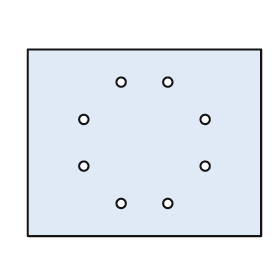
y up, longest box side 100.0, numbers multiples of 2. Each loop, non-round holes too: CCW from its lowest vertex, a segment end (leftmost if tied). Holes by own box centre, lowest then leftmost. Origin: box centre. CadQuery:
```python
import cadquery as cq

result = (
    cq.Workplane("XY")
    .moveTo(-50.0, -40.0)
    .lineTo(50.0, -40.0)
    .lineTo(50.0, 40.0)
    .lineTo(-50.0, 40.0)
    .close()
    .moveTo(-10.0, -26.0)
    .circle(2.0)
    .moveTo(10.0, -26.0)
    .circle(2.0)
    .moveTo(-26.0, -10.0)
    .circle(2.0)
    .moveTo(26.0, -10.0)
    .circle(2.0)
    .moveTo(-26.0, 10.0)
    .circle(2.0)
    .moveTo(26.0, 10.0)
    .circle(2.0)
    .moveTo(-10.0, 26.0)
    .circle(2.0)
    .moveTo(10.0, 26.0)
    .circle(2.0)
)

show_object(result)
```